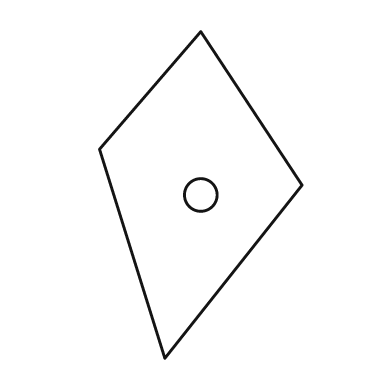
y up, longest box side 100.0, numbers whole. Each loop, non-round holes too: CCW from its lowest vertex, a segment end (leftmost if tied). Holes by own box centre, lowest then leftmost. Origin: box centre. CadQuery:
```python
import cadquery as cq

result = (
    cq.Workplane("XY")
    .moveTo(-11.0, -50.0)
    .lineTo(31.0, 3.0)
    .lineTo(0.0, 50.0)
    .lineTo(-31.0, 14.0)
    .close()
    .moveTo(0.0, 0.0)
    .circle(5.0)
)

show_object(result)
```